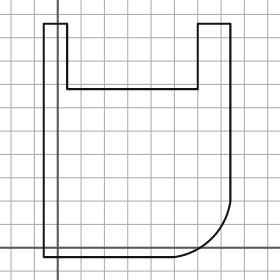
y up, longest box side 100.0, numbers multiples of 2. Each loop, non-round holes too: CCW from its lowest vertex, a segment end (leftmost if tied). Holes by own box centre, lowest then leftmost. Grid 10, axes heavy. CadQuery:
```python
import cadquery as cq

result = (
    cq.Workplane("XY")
    .moveTo(-6.0, -4.0)
    .lineTo(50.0, -4.0)
    .threePointArc((66.0, 4.0), (74.0, 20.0))
    .lineTo(74.0, 96.0)
    .lineTo(60.0, 96.0)
    .lineTo(60.0, 68.0)
    .lineTo(4.0, 68.0)
    .lineTo(4.0, 96.0)
    .lineTo(-6.0, 96.0)
    .close()
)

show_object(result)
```